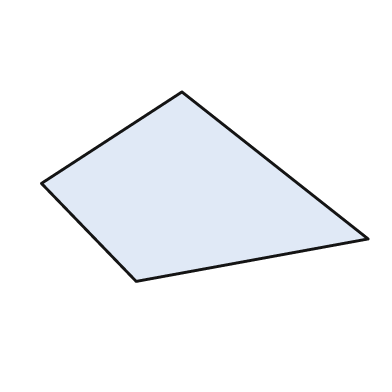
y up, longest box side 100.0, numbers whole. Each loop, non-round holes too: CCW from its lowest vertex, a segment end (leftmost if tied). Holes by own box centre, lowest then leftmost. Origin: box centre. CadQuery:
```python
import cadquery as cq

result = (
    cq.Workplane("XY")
    .moveTo(-21.0, -29.0)
    .lineTo(50.0, -16.0)
    .lineTo(-7.0, 29.0)
    .lineTo(-50.0, 1.0)
    .close()
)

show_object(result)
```